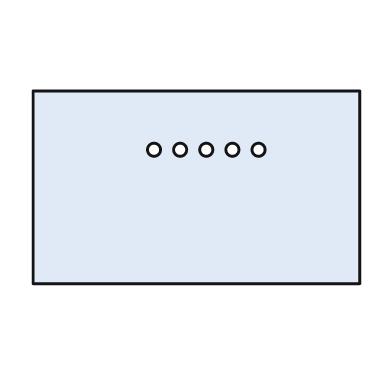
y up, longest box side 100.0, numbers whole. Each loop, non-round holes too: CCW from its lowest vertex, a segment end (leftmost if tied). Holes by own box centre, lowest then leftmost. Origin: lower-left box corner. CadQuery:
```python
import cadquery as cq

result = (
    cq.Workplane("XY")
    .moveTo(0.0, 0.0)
    .lineTo(100.0, 0.0)
    .lineTo(100.0, 59.0)
    .lineTo(0.0, 59.0)
    .close()
    .moveTo(37.0, 41.0)
    .circle(2.0)
    .moveTo(45.0, 41.0)
    .circle(2.0)
    .moveTo(53.0, 41.0)
    .circle(2.0)
    .moveTo(61.0, 41.0)
    .circle(2.0)
    .moveTo(69.0, 41.0)
    .circle(2.0)
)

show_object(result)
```